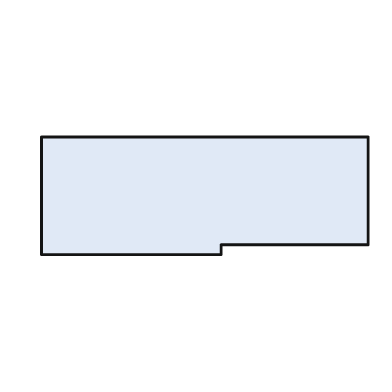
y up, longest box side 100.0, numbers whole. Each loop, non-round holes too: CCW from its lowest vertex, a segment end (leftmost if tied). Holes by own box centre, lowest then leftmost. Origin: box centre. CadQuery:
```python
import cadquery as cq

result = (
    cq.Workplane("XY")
    .moveTo(-50.0, -18.0)
    .lineTo(5.0, -18.0)
    .lineTo(5.0, -15.0)
    .lineTo(50.0, -15.0)
    .lineTo(50.0, 18.0)
    .lineTo(-50.0, 18.0)
    .close()
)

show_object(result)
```